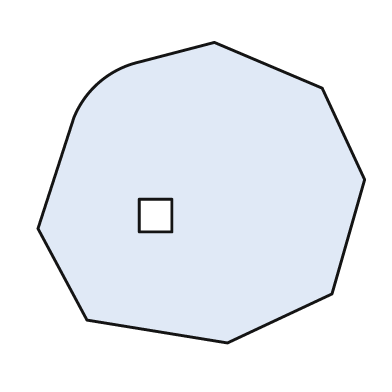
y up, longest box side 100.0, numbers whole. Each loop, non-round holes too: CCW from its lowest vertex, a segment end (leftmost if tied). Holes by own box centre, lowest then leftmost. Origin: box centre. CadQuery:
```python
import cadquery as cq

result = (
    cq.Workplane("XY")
    .moveTo(8.0, -46.0)
    .lineTo(40.0, -31.0)
    .lineTo(50.0, 4.0)
    .lineTo(37.0, 32.0)
    .lineTo(4.0, 46.0)
    .lineTo(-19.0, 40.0)
    .threePointArc((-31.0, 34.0), (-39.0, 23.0))
    .lineTo(-50.0, -11.0)
    .lineTo(-35.0, -39.0)
    .close()
    .moveTo(-19.0, -12.0)
    .lineTo(-9.0, -12.0)
    .lineTo(-9.0, -2.0)
    .lineTo(-19.0, -2.0)
    .close()
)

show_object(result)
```